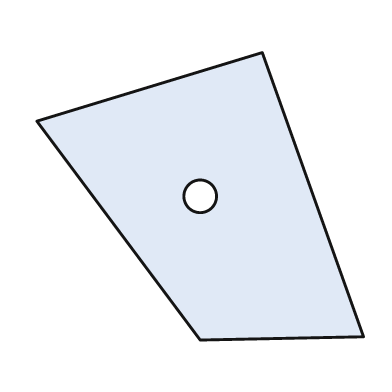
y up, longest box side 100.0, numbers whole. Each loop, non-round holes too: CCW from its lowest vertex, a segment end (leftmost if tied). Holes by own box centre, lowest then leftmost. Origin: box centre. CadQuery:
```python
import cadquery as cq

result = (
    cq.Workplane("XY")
    .moveTo(0.0, -44.0)
    .lineTo(50.0, -43.0)
    .lineTo(19.0, 44.0)
    .lineTo(-50.0, 23.0)
    .close()
    .moveTo(0.0, 0.0)
    .circle(5.0)
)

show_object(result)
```